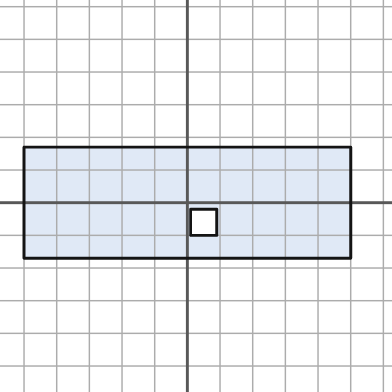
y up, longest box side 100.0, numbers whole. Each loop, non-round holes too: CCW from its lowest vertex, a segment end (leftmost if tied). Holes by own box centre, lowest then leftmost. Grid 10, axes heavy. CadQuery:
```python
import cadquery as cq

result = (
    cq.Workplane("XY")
    .moveTo(-50.0, -17.0)
    .lineTo(50.0, -17.0)
    .lineTo(50.0, 17.0)
    .lineTo(-50.0, 17.0)
    .close()
    .moveTo(1.0, -10.0)
    .lineTo(9.0, -10.0)
    .lineTo(9.0, -2.0)
    .lineTo(1.0, -2.0)
    .close()
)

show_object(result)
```